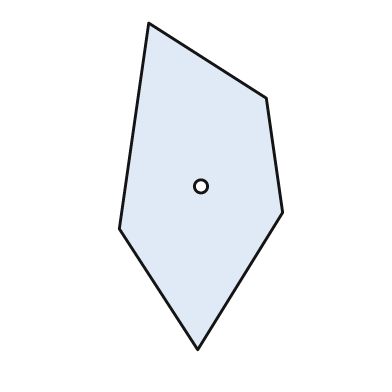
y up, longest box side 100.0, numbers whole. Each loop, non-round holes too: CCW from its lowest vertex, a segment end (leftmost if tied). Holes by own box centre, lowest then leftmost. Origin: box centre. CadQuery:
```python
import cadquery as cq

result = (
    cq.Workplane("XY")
    .moveTo(-1.0, -50.0)
    .lineTo(25.0, -8.0)
    .lineTo(20.0, 27.0)
    .lineTo(-16.0, 50.0)
    .lineTo(-25.0, -13.0)
    .close()
    .moveTo(0.0, 0.0)
    .circle(2.0)
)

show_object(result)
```